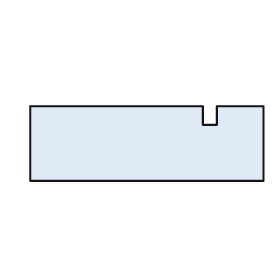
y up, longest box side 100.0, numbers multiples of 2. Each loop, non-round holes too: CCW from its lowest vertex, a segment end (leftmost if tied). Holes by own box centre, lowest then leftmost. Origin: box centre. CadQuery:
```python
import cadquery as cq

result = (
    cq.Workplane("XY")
    .moveTo(-50.0, -16.0)
    .lineTo(50.0, -16.0)
    .lineTo(50.0, 16.0)
    .lineTo(30.0, 16.0)
    .lineTo(30.0, 8.0)
    .lineTo(24.0, 8.0)
    .lineTo(24.0, 16.0)
    .lineTo(-50.0, 16.0)
    .close()
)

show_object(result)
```